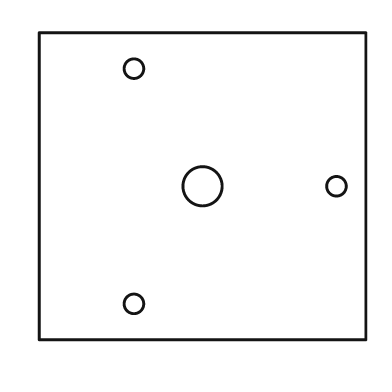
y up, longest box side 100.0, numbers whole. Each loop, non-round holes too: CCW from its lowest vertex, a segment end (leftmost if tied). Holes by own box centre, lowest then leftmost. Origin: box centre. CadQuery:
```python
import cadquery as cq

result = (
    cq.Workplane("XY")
    .moveTo(-50.0, -47.0)
    .lineTo(50.0, -47.0)
    .lineTo(50.0, 47.0)
    .lineTo(-50.0, 47.0)
    .close()
    .moveTo(-21.0, -36.0)
    .circle(3.0)
    .moveTo(0.0, 0.0)
    .circle(6.0)
    .moveTo(41.0, 0.0)
    .circle(3.0)
    .moveTo(-21.0, 36.0)
    .circle(3.0)
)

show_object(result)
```